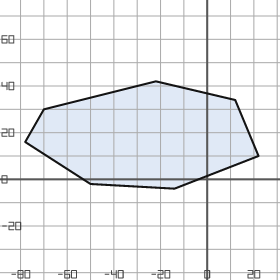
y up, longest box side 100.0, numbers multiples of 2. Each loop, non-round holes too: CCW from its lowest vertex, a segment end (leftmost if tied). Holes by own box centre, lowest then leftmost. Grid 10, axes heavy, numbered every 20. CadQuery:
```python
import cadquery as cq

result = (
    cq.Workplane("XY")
    .moveTo(-14.0, -4.0)
    .lineTo(22.0, 10.0)
    .lineTo(12.0, 34.0)
    .lineTo(-22.0, 42.0)
    .lineTo(-70.0, 30.0)
    .lineTo(-78.0, 16.0)
    .lineTo(-50.0, -2.0)
    .close()
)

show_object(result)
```